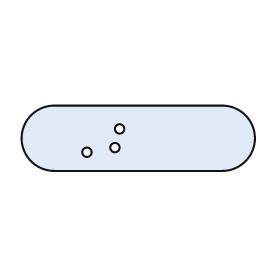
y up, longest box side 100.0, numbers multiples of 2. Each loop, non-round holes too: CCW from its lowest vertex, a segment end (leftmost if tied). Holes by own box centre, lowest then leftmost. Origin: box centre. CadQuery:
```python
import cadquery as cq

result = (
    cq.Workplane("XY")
    .moveTo(-36.0, -14.0)
    .lineTo(36.0, -14.0)
    .threePointArc((50.0, 0.0), (36.0, 14.0))
    .lineTo(-36.0, 14.0)
    .threePointArc((-50.0, 0.0), (-36.0, -14.0))
    .close()
    .moveTo(-22.0, -6.0)
    .circle(2.0)
    .moveTo(-10.0, -4.0)
    .circle(2.0)
    .moveTo(-8.0, 4.0)
    .circle(2.0)
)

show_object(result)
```